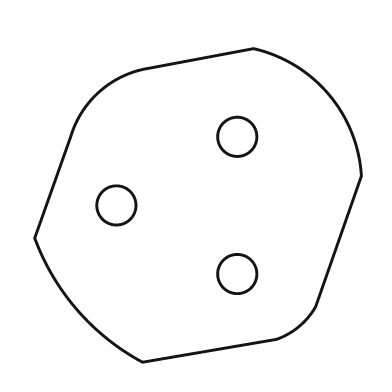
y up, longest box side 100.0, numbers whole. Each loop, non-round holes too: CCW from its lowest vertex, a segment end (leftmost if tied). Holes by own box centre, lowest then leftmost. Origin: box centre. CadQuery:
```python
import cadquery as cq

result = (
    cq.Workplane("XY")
    .moveTo(-17.0, -48.0)
    .lineTo(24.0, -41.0)
    .threePointArc((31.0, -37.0), (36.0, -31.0))
    .lineTo(50.0, 9.0)
    .threePointArc((40.0, 34.0), (17.0, 48.0))
    .lineTo(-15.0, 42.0)
    .threePointArc((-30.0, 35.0), (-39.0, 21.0))
    .lineTo(-50.0, -10.0)
    .threePointArc((-37.0, -32.0), (-17.0, -48.0))
    .close()
    .moveTo(12.0, -21.0)
    .circle(6.0)
    .moveTo(-25.0, 0.0)
    .circle(6.0)
    .moveTo(12.0, 21.0)
    .circle(6.0)
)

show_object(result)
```